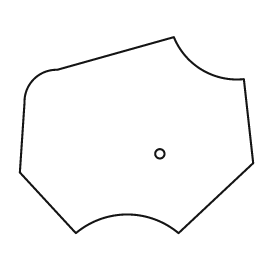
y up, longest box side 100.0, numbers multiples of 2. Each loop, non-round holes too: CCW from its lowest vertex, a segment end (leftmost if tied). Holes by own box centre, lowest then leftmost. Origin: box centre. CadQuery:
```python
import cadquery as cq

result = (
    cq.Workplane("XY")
    .moveTo(-26.0, -42.0)
    .threePointArc((-4.0, -34.0), (18.0, -42.0))
    .lineTo(50.0, -12.0)
    .lineTo(46.0, 24.0)
    .threePointArc((28.0, 28.0), (16.0, 42.0))
    .lineTo(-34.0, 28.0)
    .threePointArc((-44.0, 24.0), (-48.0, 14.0))
    .lineTo(-50.0, -16.0)
    .close()
    .moveTo(10.0, -8.0)
    .circle(2.0)
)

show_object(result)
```